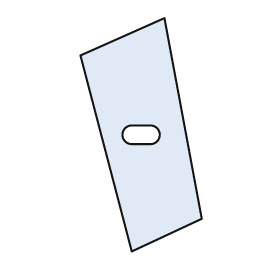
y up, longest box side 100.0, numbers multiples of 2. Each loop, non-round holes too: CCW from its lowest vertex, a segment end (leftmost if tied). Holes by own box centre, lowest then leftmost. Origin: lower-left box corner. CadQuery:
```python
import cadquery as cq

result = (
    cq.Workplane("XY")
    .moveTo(22.0, 0.0)
    .lineTo(52.0, 14.0)
    .lineTo(36.0, 100.0)
    .lineTo(0.0, 84.0)
    .close()
    .moveTo(22.0, 46.0)
    .lineTo(30.0, 46.0)
    .threePointArc((34.0, 50.0), (30.0, 54.0))
    .lineTo(22.0, 54.0)
    .threePointArc((18.0, 50.0), (22.0, 46.0))
    .close()
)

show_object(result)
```